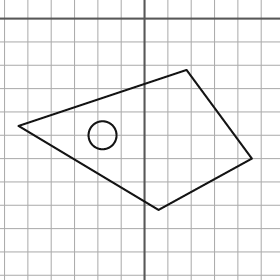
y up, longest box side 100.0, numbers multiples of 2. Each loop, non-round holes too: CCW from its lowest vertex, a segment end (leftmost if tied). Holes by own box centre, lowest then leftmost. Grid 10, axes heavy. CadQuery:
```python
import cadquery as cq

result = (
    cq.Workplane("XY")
    .moveTo(6.0, -82.0)
    .lineTo(46.0, -60.0)
    .lineTo(18.0, -22.0)
    .lineTo(-54.0, -46.0)
    .close()
    .moveTo(-18.0, -50.0)
    .circle(6.0)
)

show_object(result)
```